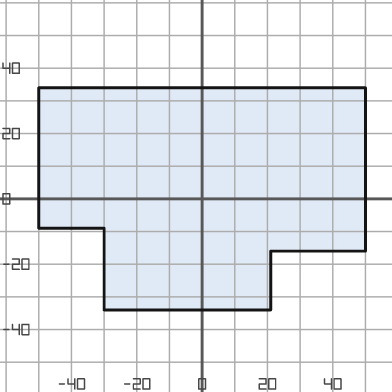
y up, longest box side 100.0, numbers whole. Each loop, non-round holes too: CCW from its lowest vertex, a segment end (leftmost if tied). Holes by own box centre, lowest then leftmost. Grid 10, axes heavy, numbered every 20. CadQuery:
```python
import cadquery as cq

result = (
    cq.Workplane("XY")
    .moveTo(-30.0, -34.0)
    .lineTo(21.0, -34.0)
    .lineTo(21.0, -16.0)
    .lineTo(50.0, -16.0)
    .lineTo(50.0, 34.0)
    .lineTo(-50.0, 34.0)
    .lineTo(-50.0, -9.0)
    .lineTo(-30.0, -9.0)
    .close()
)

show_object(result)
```